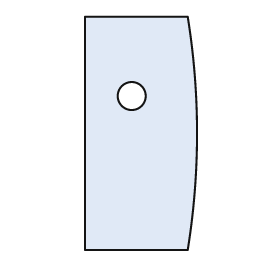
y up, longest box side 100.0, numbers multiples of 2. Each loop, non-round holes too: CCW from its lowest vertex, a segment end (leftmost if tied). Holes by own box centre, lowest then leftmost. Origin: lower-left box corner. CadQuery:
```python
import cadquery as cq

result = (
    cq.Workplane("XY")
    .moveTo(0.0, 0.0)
    .lineTo(44.0, 0.0)
    .threePointArc((48.0, 50.0), (44.0, 100.0))
    .lineTo(0.0, 100.0)
    .close()
    .moveTo(20.0, 66.0)
    .circle(6.0)
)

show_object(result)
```